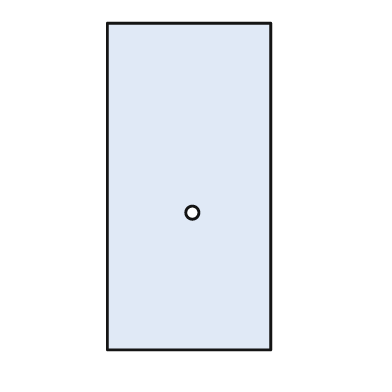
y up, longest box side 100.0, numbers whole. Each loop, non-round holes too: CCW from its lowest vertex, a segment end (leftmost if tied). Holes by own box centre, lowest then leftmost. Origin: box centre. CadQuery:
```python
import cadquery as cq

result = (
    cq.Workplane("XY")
    .moveTo(-25.0, -50.0)
    .lineTo(25.0, -50.0)
    .lineTo(25.0, 50.0)
    .lineTo(-25.0, 50.0)
    .close()
    .moveTo(1.0, -8.0)
    .circle(2.0)
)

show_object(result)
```